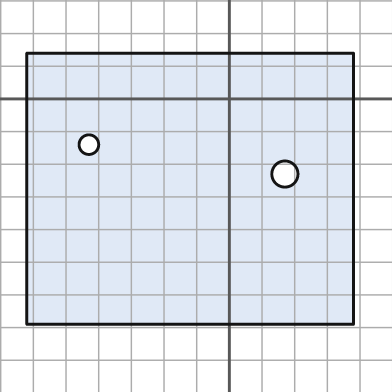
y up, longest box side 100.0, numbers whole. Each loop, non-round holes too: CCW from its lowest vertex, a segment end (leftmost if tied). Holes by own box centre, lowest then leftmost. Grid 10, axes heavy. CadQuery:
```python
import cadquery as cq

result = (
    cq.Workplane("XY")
    .moveTo(-62.0, -69.0)
    .lineTo(38.0, -69.0)
    .lineTo(38.0, 14.0)
    .lineTo(-62.0, 14.0)
    .close()
    .moveTo(17.0, -23.0)
    .circle(4.0)
    .moveTo(-43.0, -14.0)
    .circle(3.0)
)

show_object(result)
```